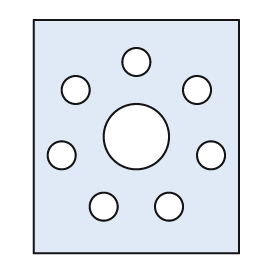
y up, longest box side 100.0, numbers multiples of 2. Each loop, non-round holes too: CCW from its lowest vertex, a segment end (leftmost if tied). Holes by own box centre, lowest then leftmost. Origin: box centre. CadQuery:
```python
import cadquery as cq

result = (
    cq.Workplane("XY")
    .moveTo(-44.0, -50.0)
    .lineTo(44.0, -50.0)
    .lineTo(44.0, 50.0)
    .lineTo(-44.0, 50.0)
    .close()
    .moveTo(-14.0, -30.0)
    .circle(6.0)
    .moveTo(14.0, -30.0)
    .circle(6.0)
    .moveTo(-32.0, -8.0)
    .circle(6.0)
    .moveTo(32.0, -8.0)
    .circle(6.0)
    .moveTo(0.0, 0.0)
    .circle(14.0)
    .moveTo(-26.0, 20.0)
    .circle(6.0)
    .moveTo(26.0, 20.0)
    .circle(6.0)
    .moveTo(0.0, 32.0)
    .circle(6.0)
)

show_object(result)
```